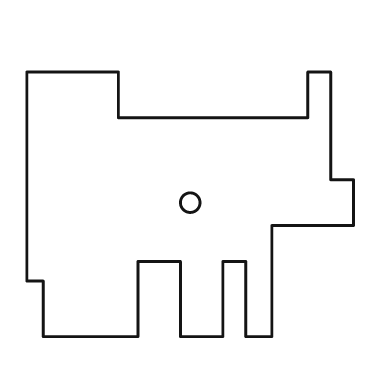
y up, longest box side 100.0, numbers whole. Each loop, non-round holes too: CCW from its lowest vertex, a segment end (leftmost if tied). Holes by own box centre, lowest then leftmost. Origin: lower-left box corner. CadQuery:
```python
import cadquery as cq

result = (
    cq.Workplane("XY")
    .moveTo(5.0, 0.0)
    .lineTo(34.0, 0.0)
    .lineTo(34.0, 23.0)
    .lineTo(47.0, 23.0)
    .lineTo(47.0, 0.0)
    .lineTo(60.0, 0.0)
    .lineTo(60.0, 23.0)
    .lineTo(67.0, 23.0)
    .lineTo(67.0, 0.0)
    .lineTo(75.0, 0.0)
    .lineTo(75.0, 34.0)
    .lineTo(100.0, 34.0)
    .lineTo(100.0, 48.0)
    .lineTo(93.0, 48.0)
    .lineTo(93.0, 81.0)
    .lineTo(86.0, 81.0)
    .lineTo(86.0, 67.0)
    .lineTo(28.0, 67.0)
    .lineTo(28.0, 81.0)
    .lineTo(0.0, 81.0)
    .lineTo(0.0, 17.0)
    .lineTo(5.0, 17.0)
    .close()
    .moveTo(50.0, 41.0)
    .circle(3.0)
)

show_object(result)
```